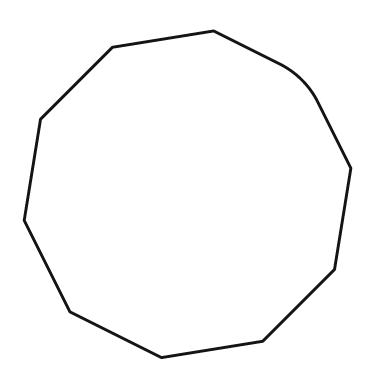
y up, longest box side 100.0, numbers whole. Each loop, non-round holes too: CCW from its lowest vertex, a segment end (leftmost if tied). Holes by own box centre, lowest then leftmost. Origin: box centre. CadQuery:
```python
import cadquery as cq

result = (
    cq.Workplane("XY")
    .moveTo(-8.0, -50.0)
    .lineTo(23.0, -45.0)
    .lineTo(45.0, -23.0)
    .lineTo(50.0, 8.0)
    .lineTo(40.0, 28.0)
    .threePointArc((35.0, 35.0), (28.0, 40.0))
    .lineTo(8.0, 50.0)
    .lineTo(-23.0, 45.0)
    .lineTo(-45.0, 23.0)
    .lineTo(-50.0, -8.0)
    .lineTo(-36.0, -36.0)
    .close()
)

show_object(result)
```